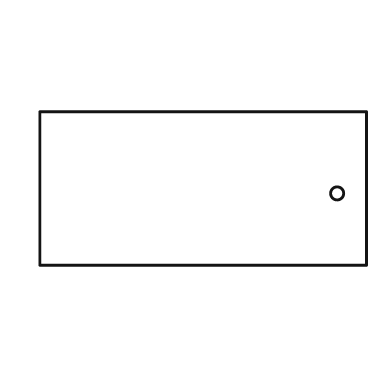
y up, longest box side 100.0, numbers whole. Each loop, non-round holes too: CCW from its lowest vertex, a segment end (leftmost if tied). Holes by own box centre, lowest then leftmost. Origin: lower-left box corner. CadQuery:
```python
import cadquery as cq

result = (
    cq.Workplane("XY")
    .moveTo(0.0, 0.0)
    .lineTo(100.0, 0.0)
    .lineTo(100.0, 47.0)
    .lineTo(0.0, 47.0)
    .close()
    .moveTo(91.0, 22.0)
    .circle(2.0)
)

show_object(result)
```